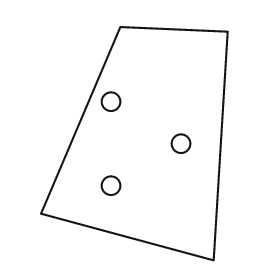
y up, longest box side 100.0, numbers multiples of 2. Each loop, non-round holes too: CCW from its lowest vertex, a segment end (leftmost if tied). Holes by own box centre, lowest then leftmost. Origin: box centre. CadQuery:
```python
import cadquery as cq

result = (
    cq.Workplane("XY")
    .moveTo(34.0, -50.0)
    .lineTo(40.0, 48.0)
    .lineTo(-6.0, 50.0)
    .lineTo(-40.0, -30.0)
    .close()
    .moveTo(-10.0, -18.0)
    .circle(4.0)
    .moveTo(20.0, 0.0)
    .circle(4.0)
    .moveTo(-10.0, 18.0)
    .circle(4.0)
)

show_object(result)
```